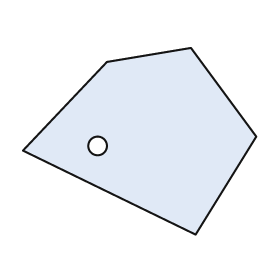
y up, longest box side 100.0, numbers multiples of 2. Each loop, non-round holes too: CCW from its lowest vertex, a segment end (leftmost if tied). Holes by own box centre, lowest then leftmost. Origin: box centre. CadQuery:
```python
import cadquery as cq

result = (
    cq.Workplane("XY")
    .moveTo(24.0, -40.0)
    .lineTo(50.0, 2.0)
    .lineTo(22.0, 40.0)
    .lineTo(-14.0, 34.0)
    .lineTo(-50.0, -4.0)
    .close()
    .moveTo(-18.0, -2.0)
    .circle(4.0)
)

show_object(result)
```